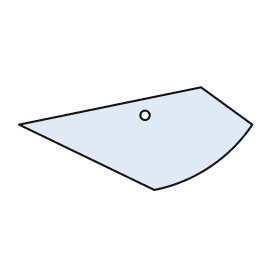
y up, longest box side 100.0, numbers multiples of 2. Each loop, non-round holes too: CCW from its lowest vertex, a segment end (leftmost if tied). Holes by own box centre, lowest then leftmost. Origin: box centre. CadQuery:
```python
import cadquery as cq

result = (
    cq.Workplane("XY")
    .moveTo(8.0, -22.0)
    .threePointArc((32.0, -12.0), (50.0, 6.0))
    .lineTo(28.0, 22.0)
    .lineTo(-50.0, 6.0)
    .close()
    .moveTo(4.0, 10.0)
    .circle(2.0)
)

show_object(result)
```